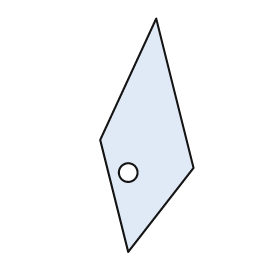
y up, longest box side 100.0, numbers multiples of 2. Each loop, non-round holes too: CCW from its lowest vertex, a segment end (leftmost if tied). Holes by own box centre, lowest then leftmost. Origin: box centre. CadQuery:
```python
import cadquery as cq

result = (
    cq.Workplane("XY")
    .moveTo(-8.0, -50.0)
    .lineTo(20.0, -14.0)
    .lineTo(4.0, 50.0)
    .lineTo(-20.0, -2.0)
    .close()
    .moveTo(-8.0, -16.0)
    .circle(4.0)
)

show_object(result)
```